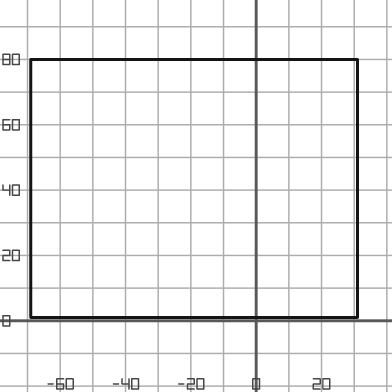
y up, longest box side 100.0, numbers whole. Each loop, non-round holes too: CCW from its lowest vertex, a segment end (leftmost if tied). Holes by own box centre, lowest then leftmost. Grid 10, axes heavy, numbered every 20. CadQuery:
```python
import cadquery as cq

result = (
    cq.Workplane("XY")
    .moveTo(-69.0, 1.0)
    .lineTo(31.0, 1.0)
    .lineTo(31.0, 80.0)
    .lineTo(-69.0, 80.0)
    .close()
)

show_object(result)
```